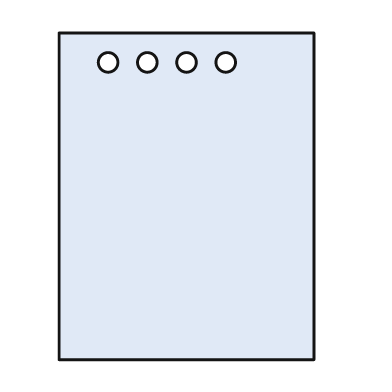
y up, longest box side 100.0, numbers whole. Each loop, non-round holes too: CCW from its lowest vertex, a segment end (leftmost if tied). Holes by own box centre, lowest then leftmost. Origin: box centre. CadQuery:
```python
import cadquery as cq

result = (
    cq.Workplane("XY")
    .moveTo(-39.0, -50.0)
    .lineTo(39.0, -50.0)
    .lineTo(39.0, 50.0)
    .lineTo(-39.0, 50.0)
    .close()
    .moveTo(-24.0, 41.0)
    .circle(3.0)
    .moveTo(-12.0, 41.0)
    .circle(3.0)
    .moveTo(0.0, 41.0)
    .circle(3.0)
    .moveTo(12.0, 41.0)
    .circle(3.0)
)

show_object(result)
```